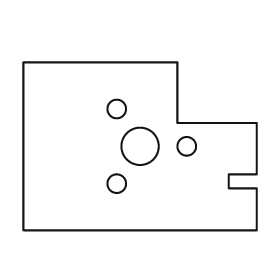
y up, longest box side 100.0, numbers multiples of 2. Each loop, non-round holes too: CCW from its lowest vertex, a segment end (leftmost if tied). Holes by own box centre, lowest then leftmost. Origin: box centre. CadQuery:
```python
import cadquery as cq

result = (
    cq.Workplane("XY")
    .moveTo(-50.0, -36.0)
    .lineTo(50.0, -36.0)
    .lineTo(50.0, -18.0)
    .lineTo(38.0, -18.0)
    .lineTo(38.0, -12.0)
    .lineTo(50.0, -12.0)
    .lineTo(50.0, 10.0)
    .lineTo(16.0, 10.0)
    .lineTo(16.0, 36.0)
    .lineTo(-50.0, 36.0)
    .close()
    .moveTo(-10.0, -16.0)
    .circle(4.0)
    .moveTo(0.0, 0.0)
    .circle(8.0)
    .moveTo(20.0, 0.0)
    .circle(4.0)
    .moveTo(-10.0, 16.0)
    .circle(4.0)
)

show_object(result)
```